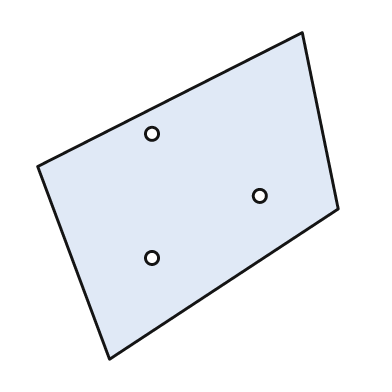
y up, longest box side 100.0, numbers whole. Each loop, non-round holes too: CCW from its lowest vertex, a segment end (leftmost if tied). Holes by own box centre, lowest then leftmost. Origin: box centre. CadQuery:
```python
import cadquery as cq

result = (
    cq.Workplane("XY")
    .moveTo(-24.0, -50.0)
    .lineTo(46.0, -4.0)
    .lineTo(35.0, 50.0)
    .lineTo(-46.0, 9.0)
    .close()
    .moveTo(-11.0, -19.0)
    .circle(2.0)
    .moveTo(22.0, 0.0)
    .circle(2.0)
    .moveTo(-11.0, 19.0)
    .circle(2.0)
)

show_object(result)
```